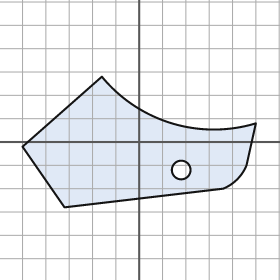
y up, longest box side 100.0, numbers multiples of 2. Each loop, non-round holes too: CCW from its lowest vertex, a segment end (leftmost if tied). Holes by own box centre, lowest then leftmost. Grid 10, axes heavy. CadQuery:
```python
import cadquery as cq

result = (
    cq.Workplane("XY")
    .moveTo(-32.0, -28.0)
    .lineTo(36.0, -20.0)
    .threePointArc((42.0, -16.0), (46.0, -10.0))
    .lineTo(50.0, 8.0)
    .threePointArc((14.0, 8.0), (-16.0, 28.0))
    .lineTo(-50.0, -2.0)
    .close()
    .moveTo(18.0, -12.0)
    .circle(4.0)
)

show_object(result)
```